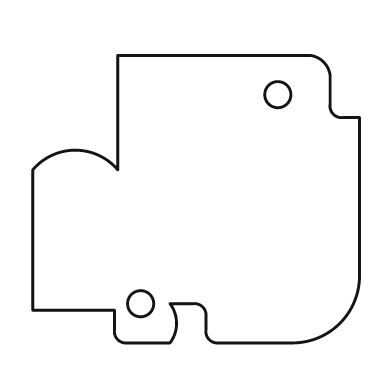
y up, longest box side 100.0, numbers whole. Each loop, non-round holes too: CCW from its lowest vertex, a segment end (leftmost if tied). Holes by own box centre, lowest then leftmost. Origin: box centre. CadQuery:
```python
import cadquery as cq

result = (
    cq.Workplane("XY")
    .moveTo(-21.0, -44.0)
    .lineTo(-8.0, -44.0)
    .threePointArc((-6.0, -38.0), (-8.0, -32.0))
    .lineTo(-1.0, -32.0)
    .threePointArc((2.0, -33.0), (3.0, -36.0))
    .lineTo(3.0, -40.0)
    .threePointArc((4.0, -43.0), (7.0, -44.0))
    .lineTo(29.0, -44.0)
    .threePointArc((44.0, -38.0), (50.0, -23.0))
    .lineTo(50.0, 25.0)
    .lineTo(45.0, 25.0)
    .threePointArc((42.0, 26.0), (41.0, 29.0))
    .lineTo(41.0, 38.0)
    .threePointArc((39.0, 42.0), (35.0, 44.0))
    .lineTo(-24.0, 44.0)
    .lineTo(-24.0, 9.0)
    .threePointArc((-37.0, 15.0), (-50.0, 9.0))
    .lineTo(-50.0, -34.0)
    .lineTo(-25.0, -34.0)
    .lineTo(-25.0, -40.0)
    .threePointArc((-24.0, -43.0), (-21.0, -44.0))
    .close()
    .moveTo(-17.0, -32.0)
    .circle(4.0)
    .moveTo(25.0, 32.0)
    .circle(4.0)
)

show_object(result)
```